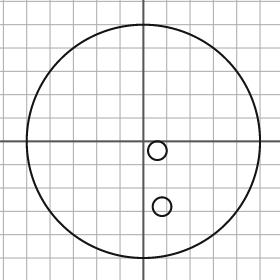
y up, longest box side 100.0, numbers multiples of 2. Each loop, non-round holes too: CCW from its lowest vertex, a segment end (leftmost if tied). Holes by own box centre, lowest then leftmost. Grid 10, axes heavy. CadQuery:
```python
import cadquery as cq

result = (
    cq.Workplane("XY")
    .moveTo(0.0, 0.0)
    .circle(50.0)
    .moveTo(8.0, -28.0)
    .circle(4.0)
    .moveTo(6.0, -4.0)
    .circle(4.0)
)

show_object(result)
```